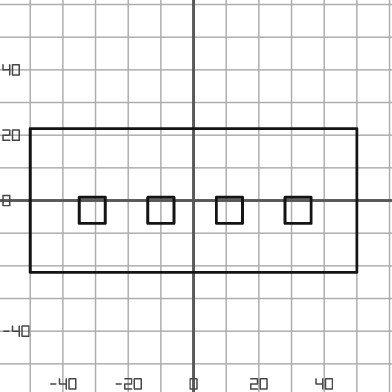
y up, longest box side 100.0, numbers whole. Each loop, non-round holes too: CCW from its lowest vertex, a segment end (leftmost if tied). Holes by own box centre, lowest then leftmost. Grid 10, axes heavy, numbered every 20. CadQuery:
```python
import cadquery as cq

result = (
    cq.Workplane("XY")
    .moveTo(-50.0, -22.0)
    .lineTo(50.0, -22.0)
    .lineTo(50.0, 22.0)
    .lineTo(-50.0, 22.0)
    .close()
    .moveTo(-35.0, -7.0)
    .lineTo(-27.0, -7.0)
    .lineTo(-27.0, 1.0)
    .lineTo(-35.0, 1.0)
    .close()
    .moveTo(-14.0, -7.0)
    .lineTo(-6.0, -7.0)
    .lineTo(-6.0, 1.0)
    .lineTo(-14.0, 1.0)
    .close()
    .moveTo(7.0, -7.0)
    .lineTo(15.0, -7.0)
    .lineTo(15.0, 1.0)
    .lineTo(7.0, 1.0)
    .close()
    .moveTo(28.0, -7.0)
    .lineTo(36.0, -7.0)
    .lineTo(36.0, 1.0)
    .lineTo(28.0, 1.0)
    .close()
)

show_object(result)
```